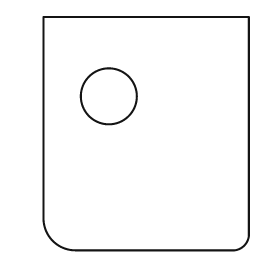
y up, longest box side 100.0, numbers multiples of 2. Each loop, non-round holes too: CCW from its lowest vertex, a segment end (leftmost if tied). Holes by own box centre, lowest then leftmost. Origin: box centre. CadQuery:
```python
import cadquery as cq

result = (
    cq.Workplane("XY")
    .moveTo(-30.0, -50.0)
    .lineTo(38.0, -50.0)
    .threePointArc((42.0, -48.0), (44.0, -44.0))
    .lineTo(44.0, 50.0)
    .lineTo(-44.0, 50.0)
    .lineTo(-44.0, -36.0)
    .threePointArc((-40.0, -46.0), (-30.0, -50.0))
    .close()
    .moveTo(-16.0, 16.0)
    .circle(12.0)
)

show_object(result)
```